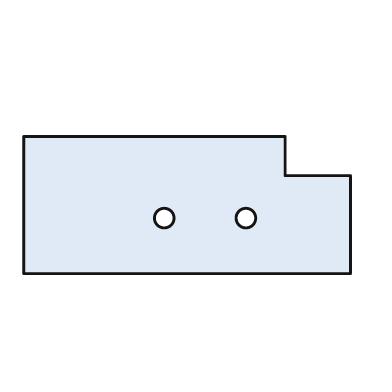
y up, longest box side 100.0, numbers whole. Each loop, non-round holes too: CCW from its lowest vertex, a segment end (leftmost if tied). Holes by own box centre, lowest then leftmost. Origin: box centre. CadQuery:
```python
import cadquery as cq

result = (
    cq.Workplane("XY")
    .moveTo(-50.0, -21.0)
    .lineTo(50.0, -21.0)
    .lineTo(50.0, 9.0)
    .lineTo(30.0, 9.0)
    .lineTo(30.0, 21.0)
    .lineTo(-50.0, 21.0)
    .close()
    .moveTo(-7.0, -4.0)
    .circle(3.0)
    .moveTo(18.0, -4.0)
    .circle(3.0)
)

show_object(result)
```